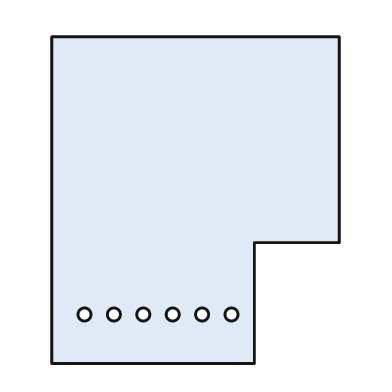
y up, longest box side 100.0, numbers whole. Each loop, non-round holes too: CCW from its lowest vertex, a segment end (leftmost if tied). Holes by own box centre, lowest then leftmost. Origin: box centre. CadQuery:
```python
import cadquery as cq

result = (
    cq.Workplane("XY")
    .moveTo(-44.0, -50.0)
    .lineTo(18.0, -50.0)
    .lineTo(18.0, -13.0)
    .lineTo(44.0, -13.0)
    .lineTo(44.0, 50.0)
    .lineTo(-44.0, 50.0)
    .close()
    .moveTo(-34.0, -35.0)
    .circle(2.0)
    .moveTo(-25.0, -35.0)
    .circle(2.0)
    .moveTo(-16.0, -35.0)
    .circle(2.0)
    .moveTo(-7.0, -35.0)
    .circle(2.0)
    .moveTo(2.0, -35.0)
    .circle(2.0)
    .moveTo(11.0, -35.0)
    .circle(2.0)
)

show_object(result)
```